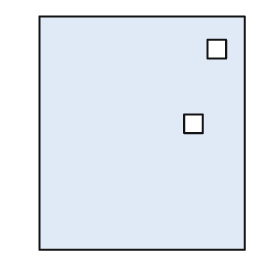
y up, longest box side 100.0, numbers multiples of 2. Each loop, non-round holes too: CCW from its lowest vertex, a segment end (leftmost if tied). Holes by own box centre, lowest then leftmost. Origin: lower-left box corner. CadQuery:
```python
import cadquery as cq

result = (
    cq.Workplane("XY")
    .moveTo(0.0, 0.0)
    .lineTo(88.0, 0.0)
    .lineTo(88.0, 100.0)
    .lineTo(0.0, 100.0)
    .close()
    .moveTo(62.0, 50.0)
    .lineTo(70.0, 50.0)
    .lineTo(70.0, 58.0)
    .lineTo(62.0, 58.0)
    .close()
    .moveTo(72.0, 82.0)
    .lineTo(80.0, 82.0)
    .lineTo(80.0, 90.0)
    .lineTo(72.0, 90.0)
    .close()
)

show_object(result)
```